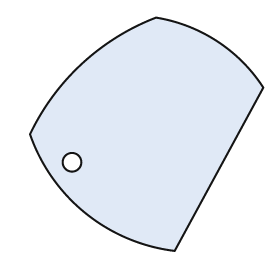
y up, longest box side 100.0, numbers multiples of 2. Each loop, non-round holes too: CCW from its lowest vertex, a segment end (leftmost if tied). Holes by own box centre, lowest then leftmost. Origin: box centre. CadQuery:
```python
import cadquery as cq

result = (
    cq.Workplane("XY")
    .moveTo(12.0, -50.0)
    .lineTo(50.0, 20.0)
    .threePointArc((30.0, 40.0), (4.0, 50.0))
    .threePointArc((-28.0, 30.0), (-50.0, 0.0))
    .threePointArc((-26.0, -34.0), (12.0, -50.0))
    .close()
    .moveTo(-32.0, -12.0)
    .circle(4.0)
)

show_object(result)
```